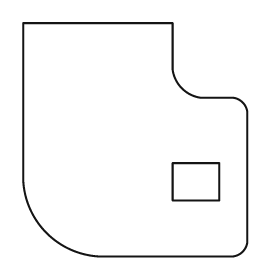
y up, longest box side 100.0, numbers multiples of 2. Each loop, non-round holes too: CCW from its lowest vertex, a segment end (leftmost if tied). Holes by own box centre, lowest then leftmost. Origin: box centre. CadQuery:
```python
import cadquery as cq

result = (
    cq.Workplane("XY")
    .moveTo(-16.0, -50.0)
    .lineTo(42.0, -50.0)
    .threePointArc((46.0, -48.0), (48.0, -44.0))
    .lineTo(48.0, 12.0)
    .threePointArc((46.0, 16.0), (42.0, 18.0))
    .lineTo(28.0, 18.0)
    .threePointArc((20.0, 22.0), (16.0, 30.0))
    .lineTo(16.0, 50.0)
    .lineTo(-48.0, 50.0)
    .lineTo(-48.0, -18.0)
    .threePointArc((-38.0, -40.0), (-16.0, -50.0))
    .close()
    .moveTo(16.0, -26.0)
    .lineTo(36.0, -26.0)
    .lineTo(36.0, -10.0)
    .lineTo(16.0, -10.0)
    .close()
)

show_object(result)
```